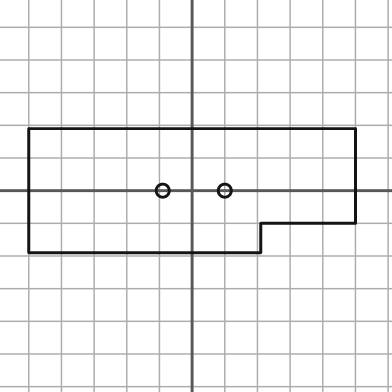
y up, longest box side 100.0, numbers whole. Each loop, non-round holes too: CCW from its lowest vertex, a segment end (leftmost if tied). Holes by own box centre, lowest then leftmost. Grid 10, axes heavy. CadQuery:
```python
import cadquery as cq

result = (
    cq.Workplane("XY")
    .moveTo(-50.0, -19.0)
    .lineTo(21.0, -19.0)
    .lineTo(21.0, -10.0)
    .lineTo(50.0, -10.0)
    .lineTo(50.0, 19.0)
    .lineTo(-50.0, 19.0)
    .close()
    .moveTo(-9.0, 0.0)
    .circle(2.0)
    .moveTo(10.0, 0.0)
    .circle(2.0)
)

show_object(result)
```